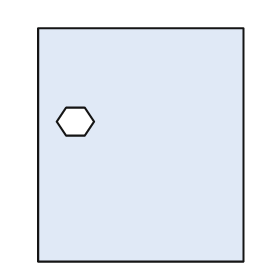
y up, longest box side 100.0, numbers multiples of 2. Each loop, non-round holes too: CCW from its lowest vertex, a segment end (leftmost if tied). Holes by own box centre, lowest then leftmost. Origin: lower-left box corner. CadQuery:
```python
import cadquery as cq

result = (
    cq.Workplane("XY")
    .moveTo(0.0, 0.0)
    .lineTo(88.0, 0.0)
    .lineTo(88.0, 100.0)
    .lineTo(0.0, 100.0)
    .close()
    .moveTo(12.0, 54.0)
    .lineTo(20.0, 54.0)
    .lineTo(24.0, 60.0)
    .lineTo(20.0, 66.0)
    .lineTo(12.0, 66.0)
    .lineTo(8.0, 60.0)
    .close()
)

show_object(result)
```